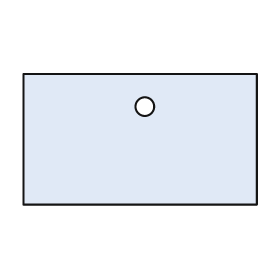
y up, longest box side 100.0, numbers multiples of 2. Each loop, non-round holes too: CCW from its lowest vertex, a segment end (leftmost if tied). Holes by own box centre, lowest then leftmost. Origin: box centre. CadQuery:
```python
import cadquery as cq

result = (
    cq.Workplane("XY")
    .moveTo(-50.0, -28.0)
    .lineTo(50.0, -28.0)
    .lineTo(50.0, 28.0)
    .lineTo(-50.0, 28.0)
    .close()
    .moveTo(2.0, 14.0)
    .circle(4.0)
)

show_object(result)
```